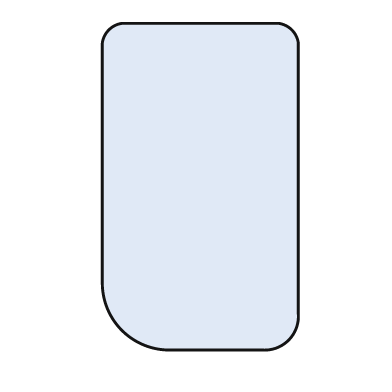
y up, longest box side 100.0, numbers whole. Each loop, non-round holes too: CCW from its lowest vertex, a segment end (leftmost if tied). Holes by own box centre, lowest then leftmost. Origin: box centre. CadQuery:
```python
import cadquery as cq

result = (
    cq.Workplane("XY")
    .moveTo(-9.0, -50.0)
    .lineTo(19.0, -50.0)
    .threePointArc((27.0, -47.0), (30.0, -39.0))
    .lineTo(30.0, 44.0)
    .threePointArc((28.0, 48.0), (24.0, 50.0))
    .lineTo(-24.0, 50.0)
    .threePointArc((-28.0, 48.0), (-30.0, 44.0))
    .lineTo(-30.0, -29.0)
    .threePointArc((-24.0, -44.0), (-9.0, -50.0))
    .close()
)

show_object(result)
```